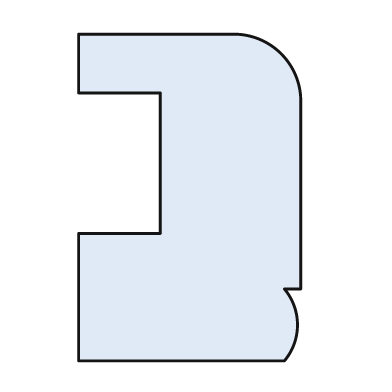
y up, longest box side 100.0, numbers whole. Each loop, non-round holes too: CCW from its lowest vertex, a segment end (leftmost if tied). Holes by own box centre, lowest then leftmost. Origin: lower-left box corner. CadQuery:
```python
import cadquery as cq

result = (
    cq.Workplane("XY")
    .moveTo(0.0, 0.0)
    .lineTo(63.0, 0.0)
    .threePointArc((67.0, 11.0), (63.0, 22.0))
    .lineTo(68.0, 22.0)
    .lineTo(68.0, 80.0)
    .threePointArc((62.0, 94.0), (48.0, 100.0))
    .lineTo(0.0, 100.0)
    .lineTo(0.0, 82.0)
    .lineTo(25.0, 82.0)
    .lineTo(25.0, 39.0)
    .lineTo(0.0, 39.0)
    .close()
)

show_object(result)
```